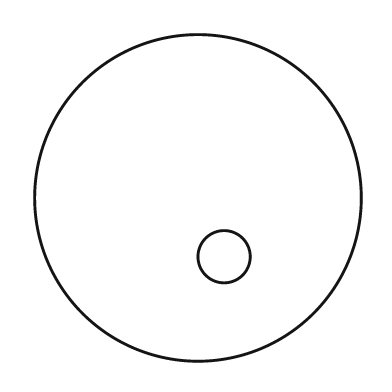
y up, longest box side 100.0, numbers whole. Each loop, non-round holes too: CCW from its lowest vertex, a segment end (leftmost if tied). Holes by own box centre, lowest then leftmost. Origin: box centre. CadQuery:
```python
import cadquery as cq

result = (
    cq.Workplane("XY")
    .moveTo(0.0, 0.0)
    .circle(50.0)
    .moveTo(8.0, -18.0)
    .circle(8.0)
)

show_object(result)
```